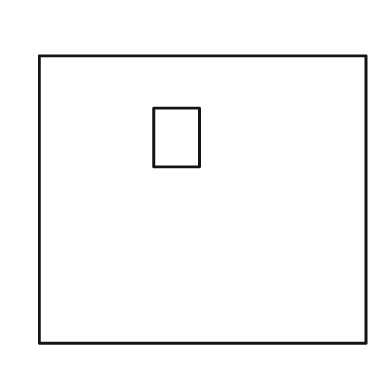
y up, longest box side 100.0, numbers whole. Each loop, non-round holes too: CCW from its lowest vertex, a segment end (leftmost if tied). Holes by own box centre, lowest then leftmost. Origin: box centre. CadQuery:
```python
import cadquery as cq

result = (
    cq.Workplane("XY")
    .moveTo(-50.0, -44.0)
    .lineTo(50.0, -44.0)
    .lineTo(50.0, 44.0)
    .lineTo(-50.0, 44.0)
    .close()
    .moveTo(-15.0, 10.0)
    .lineTo(-1.0, 10.0)
    .lineTo(-1.0, 28.0)
    .lineTo(-15.0, 28.0)
    .close()
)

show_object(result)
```